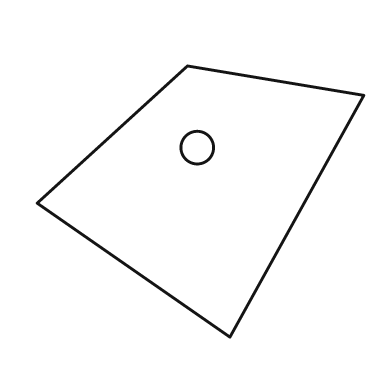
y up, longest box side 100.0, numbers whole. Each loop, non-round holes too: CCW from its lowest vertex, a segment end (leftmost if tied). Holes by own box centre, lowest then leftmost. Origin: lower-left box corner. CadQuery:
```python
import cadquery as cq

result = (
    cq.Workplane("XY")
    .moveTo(59.0, 0.0)
    .lineTo(100.0, 74.0)
    .lineTo(46.0, 83.0)
    .lineTo(0.0, 41.0)
    .close()
    .moveTo(49.0, 58.0)
    .circle(5.0)
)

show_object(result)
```